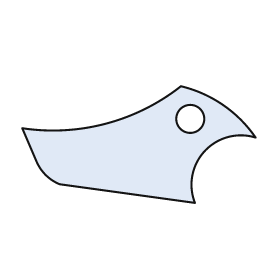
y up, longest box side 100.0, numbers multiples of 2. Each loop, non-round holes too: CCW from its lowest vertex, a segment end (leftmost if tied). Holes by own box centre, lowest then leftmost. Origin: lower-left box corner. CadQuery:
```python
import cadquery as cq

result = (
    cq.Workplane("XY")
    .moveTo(74.0, 0.0)
    .threePointArc((78.0, 22.0), (100.0, 28.0))
    .threePointArc((86.0, 42.0), (68.0, 50.0))
    .threePointArc((36.0, 34.0), (0.0, 32.0))
    .lineTo(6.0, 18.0)
    .threePointArc((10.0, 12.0), (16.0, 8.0))
    .close()
    .moveTo(72.0, 36.0)
    .circle(6.0)
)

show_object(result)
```